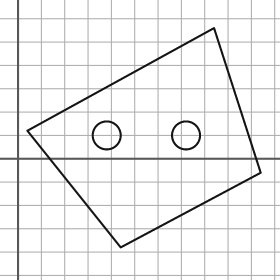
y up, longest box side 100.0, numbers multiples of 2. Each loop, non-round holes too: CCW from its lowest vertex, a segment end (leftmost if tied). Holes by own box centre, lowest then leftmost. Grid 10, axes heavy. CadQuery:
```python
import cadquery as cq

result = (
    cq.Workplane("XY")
    .moveTo(44.0, -38.0)
    .lineTo(104.0, -6.0)
    .lineTo(84.0, 56.0)
    .lineTo(4.0, 12.0)
    .close()
    .moveTo(38.0, 10.0)
    .circle(6.0)
    .moveTo(72.0, 10.0)
    .circle(6.0)
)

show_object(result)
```